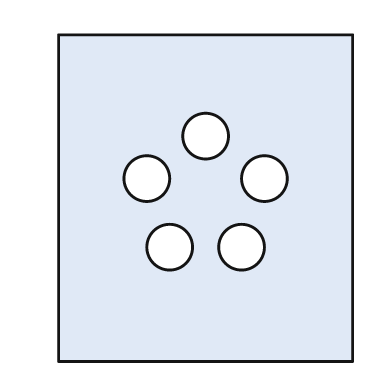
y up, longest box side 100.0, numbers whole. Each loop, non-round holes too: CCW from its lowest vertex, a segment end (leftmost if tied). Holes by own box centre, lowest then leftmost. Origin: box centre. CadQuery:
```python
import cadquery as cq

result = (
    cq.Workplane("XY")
    .moveTo(-45.0, -50.0)
    .lineTo(45.0, -50.0)
    .lineTo(45.0, 50.0)
    .lineTo(-45.0, 50.0)
    .close()
    .moveTo(-11.0, -15.0)
    .circle(7.0)
    .moveTo(11.0, -15.0)
    .circle(7.0)
    .moveTo(-18.0, 6.0)
    .circle(7.0)
    .moveTo(18.0, 6.0)
    .circle(7.0)
    .moveTo(0.0, 19.0)
    .circle(7.0)
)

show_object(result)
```